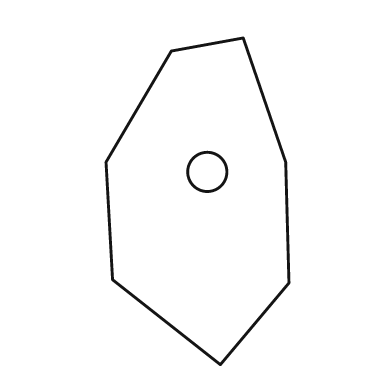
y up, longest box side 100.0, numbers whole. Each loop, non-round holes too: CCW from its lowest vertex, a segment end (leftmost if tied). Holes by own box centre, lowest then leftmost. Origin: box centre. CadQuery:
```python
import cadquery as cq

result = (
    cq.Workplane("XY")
    .moveTo(7.0, -50.0)
    .lineTo(28.0, -25.0)
    .lineTo(27.0, 12.0)
    .lineTo(14.0, 50.0)
    .lineTo(-8.0, 46.0)
    .lineTo(-28.0, 12.0)
    .lineTo(-26.0, -24.0)
    .close()
    .moveTo(3.0, 9.0)
    .circle(6.0)
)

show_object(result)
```